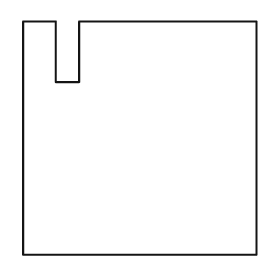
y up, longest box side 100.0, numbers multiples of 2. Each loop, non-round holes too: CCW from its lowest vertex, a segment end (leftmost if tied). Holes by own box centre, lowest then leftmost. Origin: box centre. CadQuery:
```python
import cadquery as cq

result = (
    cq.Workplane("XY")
    .moveTo(-50.0, -50.0)
    .lineTo(50.0, -50.0)
    .lineTo(50.0, 50.0)
    .lineTo(-26.0, 50.0)
    .lineTo(-26.0, 24.0)
    .lineTo(-36.0, 24.0)
    .lineTo(-36.0, 50.0)
    .lineTo(-50.0, 50.0)
    .close()
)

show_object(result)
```